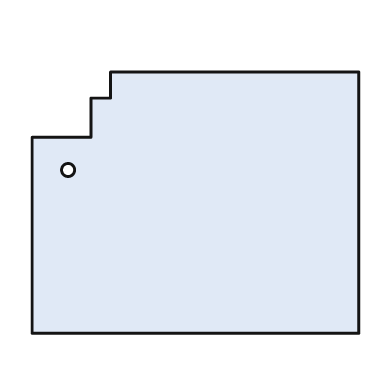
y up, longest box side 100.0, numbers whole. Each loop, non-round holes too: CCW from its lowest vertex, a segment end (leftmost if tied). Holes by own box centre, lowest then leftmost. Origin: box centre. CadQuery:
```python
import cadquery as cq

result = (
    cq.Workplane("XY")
    .moveTo(-50.0, -40.0)
    .lineTo(50.0, -40.0)
    .lineTo(50.0, 40.0)
    .lineTo(-26.0, 40.0)
    .lineTo(-26.0, 32.0)
    .lineTo(-32.0, 32.0)
    .lineTo(-32.0, 20.0)
    .lineTo(-50.0, 20.0)
    .close()
    .moveTo(-39.0, 10.0)
    .circle(2.0)
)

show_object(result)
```